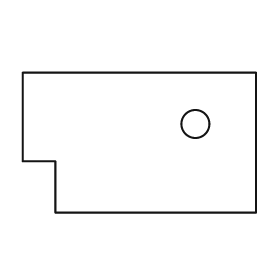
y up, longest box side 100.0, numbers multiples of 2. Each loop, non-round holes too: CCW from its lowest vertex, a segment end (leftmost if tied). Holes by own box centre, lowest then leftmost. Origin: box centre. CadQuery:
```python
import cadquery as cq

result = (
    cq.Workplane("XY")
    .moveTo(-36.0, -30.0)
    .lineTo(50.0, -30.0)
    .lineTo(50.0, 30.0)
    .lineTo(-50.0, 30.0)
    .lineTo(-50.0, -8.0)
    .lineTo(-36.0, -8.0)
    .close()
    .moveTo(24.0, 8.0)
    .circle(6.0)
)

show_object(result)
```